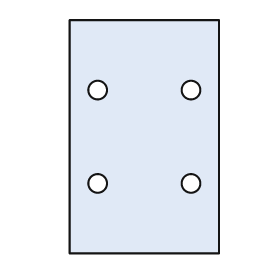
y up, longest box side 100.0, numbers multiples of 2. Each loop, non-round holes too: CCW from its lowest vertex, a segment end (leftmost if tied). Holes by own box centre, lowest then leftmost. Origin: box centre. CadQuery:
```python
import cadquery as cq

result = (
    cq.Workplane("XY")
    .moveTo(-32.0, -50.0)
    .lineTo(32.0, -50.0)
    .lineTo(32.0, 50.0)
    .lineTo(-32.0, 50.0)
    .close()
    .moveTo(-20.0, -20.0)
    .circle(4.0)
    .moveTo(20.0, -20.0)
    .circle(4.0)
    .moveTo(-20.0, 20.0)
    .circle(4.0)
    .moveTo(20.0, 20.0)
    .circle(4.0)
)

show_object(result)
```